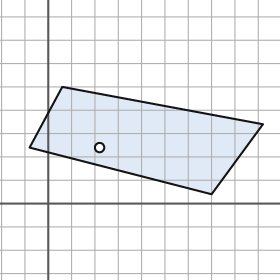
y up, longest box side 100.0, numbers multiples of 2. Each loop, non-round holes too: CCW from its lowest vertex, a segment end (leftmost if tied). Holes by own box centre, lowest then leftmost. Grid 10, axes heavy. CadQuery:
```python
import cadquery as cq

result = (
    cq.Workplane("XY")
    .moveTo(70.0, 4.0)
    .lineTo(92.0, 34.0)
    .lineTo(6.0, 50.0)
    .lineTo(-8.0, 24.0)
    .close()
    .moveTo(22.0, 24.0)
    .circle(2.0)
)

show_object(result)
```